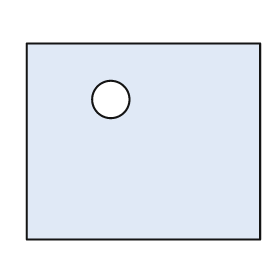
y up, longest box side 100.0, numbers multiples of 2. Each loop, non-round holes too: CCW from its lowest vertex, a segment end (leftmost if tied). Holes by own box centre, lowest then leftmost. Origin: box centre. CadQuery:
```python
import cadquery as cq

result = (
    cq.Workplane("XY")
    .moveTo(-50.0, -42.0)
    .lineTo(50.0, -42.0)
    .lineTo(50.0, 42.0)
    .lineTo(-50.0, 42.0)
    .close()
    .moveTo(-14.0, 18.0)
    .circle(8.0)
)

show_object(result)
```